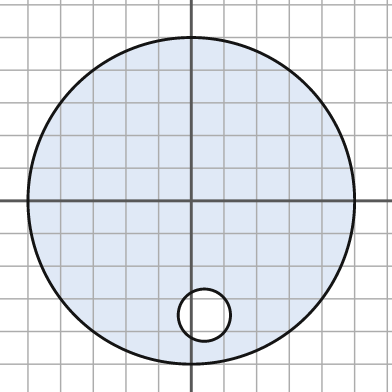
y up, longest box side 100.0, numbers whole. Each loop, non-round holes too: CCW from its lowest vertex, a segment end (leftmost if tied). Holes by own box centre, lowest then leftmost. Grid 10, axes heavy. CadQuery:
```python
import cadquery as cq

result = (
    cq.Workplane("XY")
    .moveTo(0.0, 0.0)
    .circle(50.0)
    .moveTo(4.0, -35.0)
    .circle(8.0)
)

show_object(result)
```